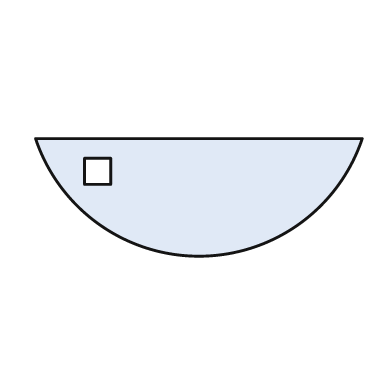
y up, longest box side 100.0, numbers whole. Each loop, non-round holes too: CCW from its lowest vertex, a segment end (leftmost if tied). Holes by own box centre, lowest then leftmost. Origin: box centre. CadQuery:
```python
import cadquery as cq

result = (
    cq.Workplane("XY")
    .moveTo(-50.0, 18.0)
    .threePointArc((0.0, -18.0), (50.0, 18.0))
    .close()
    .moveTo(-35.0, 4.0)
    .lineTo(-27.0, 4.0)
    .lineTo(-27.0, 12.0)
    .lineTo(-35.0, 12.0)
    .close()
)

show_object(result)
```